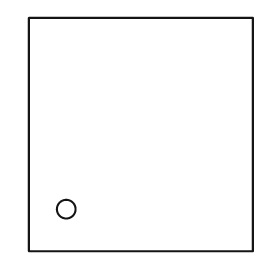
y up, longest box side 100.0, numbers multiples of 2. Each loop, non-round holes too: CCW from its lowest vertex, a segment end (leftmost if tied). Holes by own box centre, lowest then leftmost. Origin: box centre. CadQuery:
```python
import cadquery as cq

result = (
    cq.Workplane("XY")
    .moveTo(-48.0, -50.0)
    .lineTo(48.0, -50.0)
    .lineTo(48.0, 50.0)
    .lineTo(-48.0, 50.0)
    .close()
    .moveTo(-32.0, -32.0)
    .circle(4.0)
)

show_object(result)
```